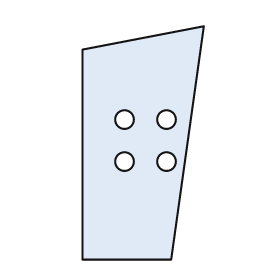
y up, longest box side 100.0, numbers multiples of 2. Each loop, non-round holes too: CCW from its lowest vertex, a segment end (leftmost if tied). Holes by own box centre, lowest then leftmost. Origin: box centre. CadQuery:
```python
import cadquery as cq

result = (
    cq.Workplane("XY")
    .moveTo(-26.0, -50.0)
    .lineTo(12.0, -50.0)
    .lineTo(26.0, 50.0)
    .lineTo(-26.0, 40.0)
    .close()
    .moveTo(-8.0, -8.0)
    .circle(4.0)
    .moveTo(10.0, -8.0)
    .circle(4.0)
    .moveTo(-8.0, 10.0)
    .circle(4.0)
    .moveTo(10.0, 10.0)
    .circle(4.0)
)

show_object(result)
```